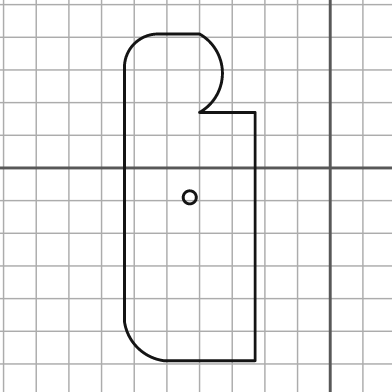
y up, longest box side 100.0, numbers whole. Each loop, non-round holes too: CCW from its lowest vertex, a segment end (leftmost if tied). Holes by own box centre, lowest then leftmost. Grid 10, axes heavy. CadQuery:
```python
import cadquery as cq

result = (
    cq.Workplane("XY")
    .moveTo(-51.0, -59.0)
    .lineTo(-23.0, -59.0)
    .lineTo(-23.0, 17.0)
    .lineTo(-40.0, 17.0)
    .threePointArc((-33.0, 29.0), (-40.0, 41.0))
    .lineTo(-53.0, 41.0)
    .threePointArc((-60.0, 38.0), (-63.0, 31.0))
    .lineTo(-63.0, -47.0)
    .threePointArc((-59.0, -55.0), (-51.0, -59.0))
    .close()
    .moveTo(-43.0, -9.0)
    .circle(2.0)
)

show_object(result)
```